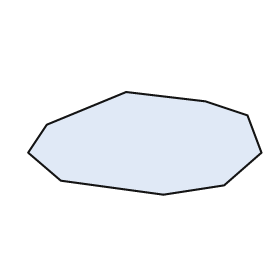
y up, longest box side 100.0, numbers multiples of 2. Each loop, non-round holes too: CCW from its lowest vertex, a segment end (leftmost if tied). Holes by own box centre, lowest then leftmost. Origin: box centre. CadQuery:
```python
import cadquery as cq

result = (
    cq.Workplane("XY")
    .moveTo(8.0, -22.0)
    .lineTo(34.0, -18.0)
    .lineTo(50.0, -4.0)
    .lineTo(44.0, 12.0)
    .lineTo(26.0, 18.0)
    .lineTo(-8.0, 22.0)
    .lineTo(-42.0, 8.0)
    .lineTo(-50.0, -4.0)
    .lineTo(-36.0, -16.0)
    .close()
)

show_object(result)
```